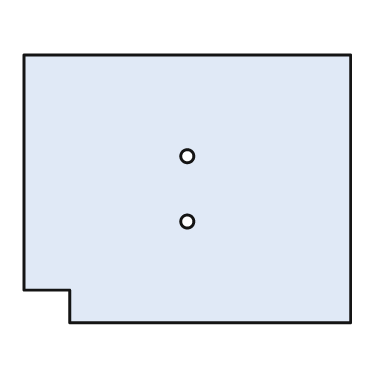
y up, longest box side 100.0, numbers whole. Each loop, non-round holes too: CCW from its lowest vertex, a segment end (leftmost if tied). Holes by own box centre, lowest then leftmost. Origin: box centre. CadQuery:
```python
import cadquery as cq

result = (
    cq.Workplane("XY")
    .moveTo(-36.0, -41.0)
    .lineTo(50.0, -41.0)
    .lineTo(50.0, 41.0)
    .lineTo(-50.0, 41.0)
    .lineTo(-50.0, -31.0)
    .lineTo(-36.0, -31.0)
    .close()
    .moveTo(0.0, -10.0)
    .circle(2.0)
    .moveTo(0.0, 10.0)
    .circle(2.0)
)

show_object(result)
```